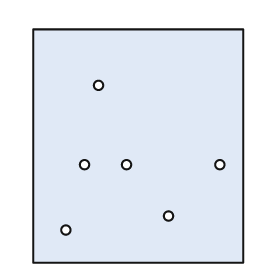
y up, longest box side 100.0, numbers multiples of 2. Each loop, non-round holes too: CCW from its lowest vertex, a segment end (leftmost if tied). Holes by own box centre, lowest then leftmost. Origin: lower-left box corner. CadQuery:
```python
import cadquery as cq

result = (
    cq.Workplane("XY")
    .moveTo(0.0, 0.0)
    .lineTo(90.0, 0.0)
    .lineTo(90.0, 100.0)
    .lineTo(0.0, 100.0)
    .close()
    .moveTo(14.0, 14.0)
    .circle(2.0)
    .moveTo(58.0, 20.0)
    .circle(2.0)
    .moveTo(22.0, 42.0)
    .circle(2.0)
    .moveTo(40.0, 42.0)
    .circle(2.0)
    .moveTo(80.0, 42.0)
    .circle(2.0)
    .moveTo(28.0, 76.0)
    .circle(2.0)
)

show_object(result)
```